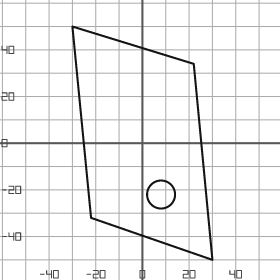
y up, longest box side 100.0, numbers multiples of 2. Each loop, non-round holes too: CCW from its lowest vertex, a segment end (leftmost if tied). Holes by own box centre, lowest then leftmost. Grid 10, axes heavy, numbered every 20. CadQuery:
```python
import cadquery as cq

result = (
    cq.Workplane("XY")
    .moveTo(30.0, -50.0)
    .lineTo(22.0, 34.0)
    .lineTo(-30.0, 50.0)
    .lineTo(-22.0, -32.0)
    .close()
    .moveTo(8.0, -22.0)
    .circle(6.0)
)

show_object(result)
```